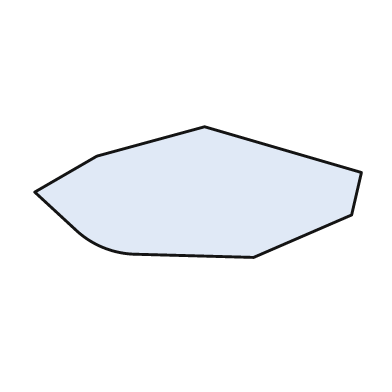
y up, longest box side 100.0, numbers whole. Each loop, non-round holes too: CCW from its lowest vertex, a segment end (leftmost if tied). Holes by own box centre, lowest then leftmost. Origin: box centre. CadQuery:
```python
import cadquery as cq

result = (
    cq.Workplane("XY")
    .moveTo(17.0, -20.0)
    .lineTo(47.0, -7.0)
    .lineTo(50.0, 6.0)
    .lineTo(2.0, 20.0)
    .lineTo(-31.0, 11.0)
    .lineTo(-50.0, 0.0)
    .lineTo(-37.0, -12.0)
    .threePointArc((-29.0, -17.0), (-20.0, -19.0))
    .close()
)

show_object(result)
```